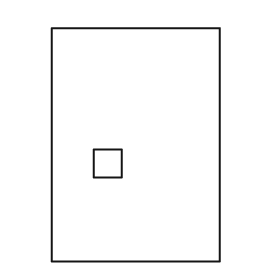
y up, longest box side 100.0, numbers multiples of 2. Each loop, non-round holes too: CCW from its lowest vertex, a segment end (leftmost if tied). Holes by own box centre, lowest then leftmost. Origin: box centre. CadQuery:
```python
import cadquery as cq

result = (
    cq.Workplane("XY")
    .moveTo(-36.0, -50.0)
    .lineTo(36.0, -50.0)
    .lineTo(36.0, 50.0)
    .lineTo(-36.0, 50.0)
    .close()
    .moveTo(-18.0, -14.0)
    .lineTo(-6.0, -14.0)
    .lineTo(-6.0, -2.0)
    .lineTo(-18.0, -2.0)
    .close()
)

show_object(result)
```